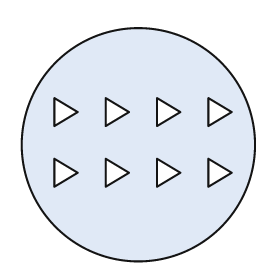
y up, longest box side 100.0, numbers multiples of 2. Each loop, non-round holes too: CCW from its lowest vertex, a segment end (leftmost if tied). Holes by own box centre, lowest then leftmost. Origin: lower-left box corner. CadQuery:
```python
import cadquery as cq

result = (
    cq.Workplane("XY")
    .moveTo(50.0, 50.0)
    .circle(50.0)
    .moveTo(14.0, 32.0)
    .lineTo(24.0, 38.0)
    .lineTo(14.0, 44.0)
    .close()
    .moveTo(36.0, 32.0)
    .lineTo(46.0, 38.0)
    .lineTo(36.0, 44.0)
    .close()
    .moveTo(58.0, 32.0)
    .lineTo(68.0, 38.0)
    .lineTo(58.0, 44.0)
    .close()
    .moveTo(80.0, 32.0)
    .lineTo(90.0, 38.0)
    .lineTo(80.0, 44.0)
    .close()
    .moveTo(14.0, 58.0)
    .lineTo(24.0, 64.0)
    .lineTo(14.0, 70.0)
    .close()
    .moveTo(36.0, 58.0)
    .lineTo(46.0, 64.0)
    .lineTo(36.0, 70.0)
    .close()
    .moveTo(58.0, 58.0)
    .lineTo(68.0, 64.0)
    .lineTo(58.0, 70.0)
    .close()
    .moveTo(80.0, 58.0)
    .lineTo(90.0, 64.0)
    .lineTo(80.0, 70.0)
    .close()
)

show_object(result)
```